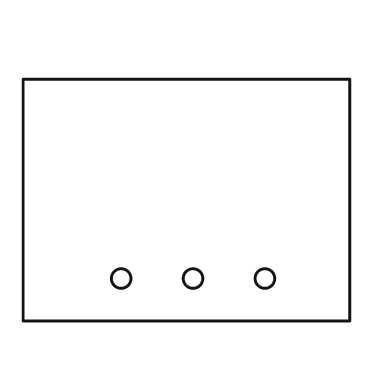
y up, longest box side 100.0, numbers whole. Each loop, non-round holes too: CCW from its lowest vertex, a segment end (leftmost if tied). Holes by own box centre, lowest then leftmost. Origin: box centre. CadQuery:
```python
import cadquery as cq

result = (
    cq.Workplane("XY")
    .moveTo(-50.0, -37.0)
    .lineTo(50.0, -37.0)
    .lineTo(50.0, 37.0)
    .lineTo(-50.0, 37.0)
    .close()
    .moveTo(-20.0, -24.0)
    .circle(3.0)
    .moveTo(2.0, -24.0)
    .circle(3.0)
    .moveTo(24.0, -24.0)
    .circle(3.0)
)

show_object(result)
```